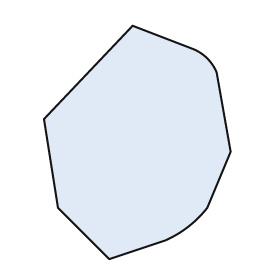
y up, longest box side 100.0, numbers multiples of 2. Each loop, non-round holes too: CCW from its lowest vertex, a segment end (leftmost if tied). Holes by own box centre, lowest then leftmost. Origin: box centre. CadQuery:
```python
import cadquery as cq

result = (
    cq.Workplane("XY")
    .moveTo(-12.0, -50.0)
    .lineTo(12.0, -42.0)
    .threePointArc((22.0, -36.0), (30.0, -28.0))
    .lineTo(40.0, -4.0)
    .lineTo(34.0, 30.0)
    .threePointArc((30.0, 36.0), (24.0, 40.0))
    .lineTo(-2.0, 50.0)
    .lineTo(-40.0, 10.0)
    .lineTo(-34.0, -28.0)
    .close()
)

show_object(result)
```